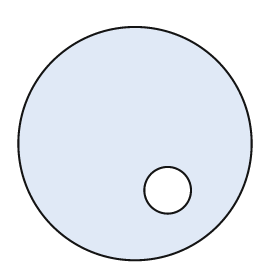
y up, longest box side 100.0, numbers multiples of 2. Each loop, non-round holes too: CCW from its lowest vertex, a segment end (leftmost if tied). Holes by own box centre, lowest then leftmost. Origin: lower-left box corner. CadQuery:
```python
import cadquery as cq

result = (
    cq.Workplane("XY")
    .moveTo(50.0, 50.0)
    .circle(50.0)
    .moveTo(64.0, 30.0)
    .circle(10.0)
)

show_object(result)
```